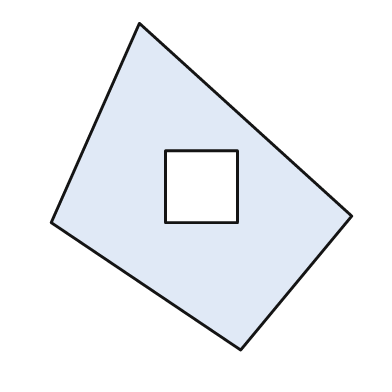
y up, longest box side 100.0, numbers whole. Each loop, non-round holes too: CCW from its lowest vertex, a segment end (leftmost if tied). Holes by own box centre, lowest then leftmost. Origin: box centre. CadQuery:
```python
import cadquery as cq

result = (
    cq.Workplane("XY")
    .moveTo(12.0, -50.0)
    .lineTo(46.0, -9.0)
    .lineTo(-19.0, 50.0)
    .lineTo(-46.0, -11.0)
    .close()
    .moveTo(-11.0, -11.0)
    .lineTo(11.0, -11.0)
    .lineTo(11.0, 11.0)
    .lineTo(-11.0, 11.0)
    .close()
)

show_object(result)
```